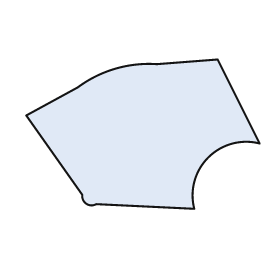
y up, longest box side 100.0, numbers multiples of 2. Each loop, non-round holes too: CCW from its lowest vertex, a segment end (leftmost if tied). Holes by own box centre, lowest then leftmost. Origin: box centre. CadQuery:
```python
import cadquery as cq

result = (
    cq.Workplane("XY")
    .moveTo(22.0, -32.0)
    .threePointArc((28.0, -10.0), (50.0, -4.0))
    .lineTo(32.0, 32.0)
    .lineTo(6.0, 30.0)
    .threePointArc((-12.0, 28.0), (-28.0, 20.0))
    .lineTo(-50.0, 8.0)
    .lineTo(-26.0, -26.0)
    .threePointArc((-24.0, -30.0), (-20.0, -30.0))
    .close()
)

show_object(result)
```